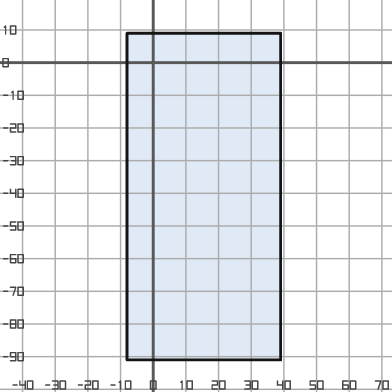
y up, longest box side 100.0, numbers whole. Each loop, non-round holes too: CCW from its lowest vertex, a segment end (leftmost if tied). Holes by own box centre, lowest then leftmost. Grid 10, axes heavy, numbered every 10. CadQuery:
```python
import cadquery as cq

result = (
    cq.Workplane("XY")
    .moveTo(-8.0, -91.0)
    .lineTo(39.0, -91.0)
    .lineTo(39.0, 9.0)
    .lineTo(-8.0, 9.0)
    .close()
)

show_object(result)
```